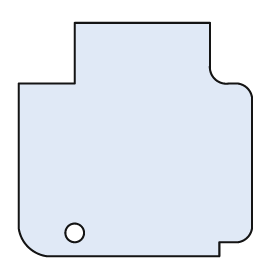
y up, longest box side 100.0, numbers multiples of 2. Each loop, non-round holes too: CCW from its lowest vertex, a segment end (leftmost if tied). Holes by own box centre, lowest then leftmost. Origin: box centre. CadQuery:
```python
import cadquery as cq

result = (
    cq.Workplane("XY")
    .moveTo(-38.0, -50.0)
    .lineTo(36.0, -50.0)
    .lineTo(36.0, -44.0)
    .lineTo(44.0, -44.0)
    .threePointArc((48.0, -42.0), (50.0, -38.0))
    .lineTo(50.0, 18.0)
    .threePointArc((48.0, 22.0), (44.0, 24.0))
    .lineTo(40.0, 24.0)
    .threePointArc((34.0, 26.0), (32.0, 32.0))
    .lineTo(32.0, 50.0)
    .lineTo(-26.0, 50.0)
    .lineTo(-26.0, 24.0)
    .lineTo(-50.0, 24.0)
    .lineTo(-50.0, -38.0)
    .threePointArc((-46.0, -46.0), (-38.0, -50.0))
    .close()
    .moveTo(-26.0, -40.0)
    .circle(4.0)
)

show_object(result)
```